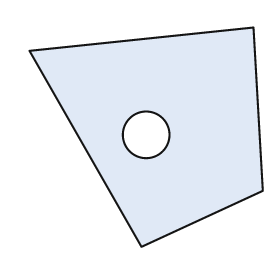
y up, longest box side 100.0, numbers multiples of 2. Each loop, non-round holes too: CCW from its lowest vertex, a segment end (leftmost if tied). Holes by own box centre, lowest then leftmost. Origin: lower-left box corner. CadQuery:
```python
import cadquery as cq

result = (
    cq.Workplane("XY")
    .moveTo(48.0, 0.0)
    .lineTo(100.0, 24.0)
    .lineTo(96.0, 94.0)
    .lineTo(0.0, 84.0)
    .close()
    .moveTo(50.0, 48.0)
    .circle(10.0)
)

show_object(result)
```